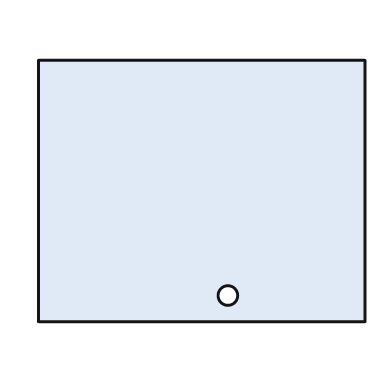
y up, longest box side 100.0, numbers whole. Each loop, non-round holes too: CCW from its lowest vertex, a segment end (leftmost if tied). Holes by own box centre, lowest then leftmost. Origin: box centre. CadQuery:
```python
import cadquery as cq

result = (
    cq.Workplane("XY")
    .moveTo(-50.0, -40.0)
    .lineTo(50.0, -40.0)
    .lineTo(50.0, 40.0)
    .lineTo(-50.0, 40.0)
    .close()
    .moveTo(8.0, -32.0)
    .circle(3.0)
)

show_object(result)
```